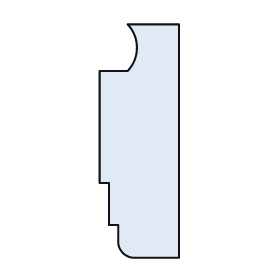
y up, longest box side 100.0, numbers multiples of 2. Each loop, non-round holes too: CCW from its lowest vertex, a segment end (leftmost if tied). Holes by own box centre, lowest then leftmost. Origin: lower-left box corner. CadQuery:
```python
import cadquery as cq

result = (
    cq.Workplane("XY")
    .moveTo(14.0, 0.0)
    .lineTo(34.0, 0.0)
    .lineTo(34.0, 100.0)
    .lineTo(12.0, 100.0)
    .threePointArc((16.0, 90.0), (12.0, 80.0))
    .lineTo(0.0, 80.0)
    .lineTo(0.0, 32.0)
    .lineTo(4.0, 32.0)
    .lineTo(4.0, 14.0)
    .lineTo(8.0, 14.0)
    .lineTo(8.0, 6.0)
    .threePointArc((10.0, 2.0), (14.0, 0.0))
    .close()
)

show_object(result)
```